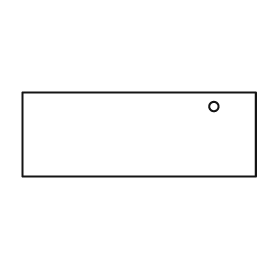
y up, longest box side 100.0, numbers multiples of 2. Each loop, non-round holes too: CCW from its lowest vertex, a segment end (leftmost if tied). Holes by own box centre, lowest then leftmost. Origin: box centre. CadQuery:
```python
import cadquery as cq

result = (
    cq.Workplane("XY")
    .moveTo(-50.0, -18.0)
    .lineTo(50.0, -18.0)
    .lineTo(50.0, 18.0)
    .lineTo(-50.0, 18.0)
    .close()
    .moveTo(32.0, 12.0)
    .circle(2.0)
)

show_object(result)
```